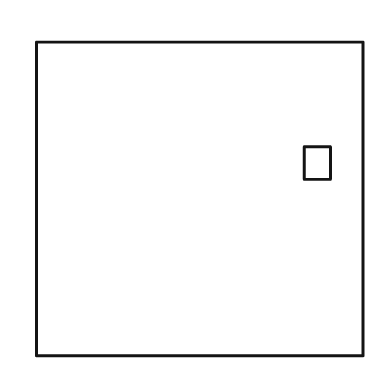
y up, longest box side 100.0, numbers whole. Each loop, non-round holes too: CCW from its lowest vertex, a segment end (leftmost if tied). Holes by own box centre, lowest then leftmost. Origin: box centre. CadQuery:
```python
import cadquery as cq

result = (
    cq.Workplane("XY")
    .moveTo(-50.0, -48.0)
    .lineTo(50.0, -48.0)
    .lineTo(50.0, 48.0)
    .lineTo(-50.0, 48.0)
    .close()
    .moveTo(32.0, 6.0)
    .lineTo(40.0, 6.0)
    .lineTo(40.0, 16.0)
    .lineTo(32.0, 16.0)
    .close()
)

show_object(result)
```